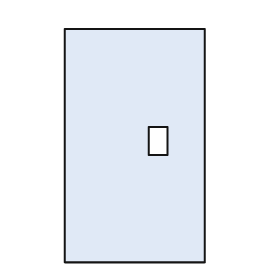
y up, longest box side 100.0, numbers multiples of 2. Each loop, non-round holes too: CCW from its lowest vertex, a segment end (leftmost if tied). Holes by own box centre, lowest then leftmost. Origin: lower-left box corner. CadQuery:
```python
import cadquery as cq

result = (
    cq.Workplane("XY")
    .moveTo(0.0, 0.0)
    .lineTo(60.0, 0.0)
    .lineTo(60.0, 100.0)
    .lineTo(0.0, 100.0)
    .close()
    .moveTo(36.0, 46.0)
    .lineTo(44.0, 46.0)
    .lineTo(44.0, 58.0)
    .lineTo(36.0, 58.0)
    .close()
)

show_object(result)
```